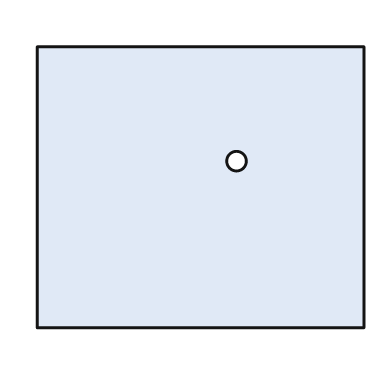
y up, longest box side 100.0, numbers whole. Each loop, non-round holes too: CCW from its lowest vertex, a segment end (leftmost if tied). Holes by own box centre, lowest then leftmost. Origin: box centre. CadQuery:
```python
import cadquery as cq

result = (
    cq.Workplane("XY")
    .moveTo(-50.0, -43.0)
    .lineTo(50.0, -43.0)
    .lineTo(50.0, 43.0)
    .lineTo(-50.0, 43.0)
    .close()
    .moveTo(11.0, 8.0)
    .circle(3.0)
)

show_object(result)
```